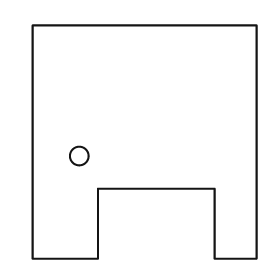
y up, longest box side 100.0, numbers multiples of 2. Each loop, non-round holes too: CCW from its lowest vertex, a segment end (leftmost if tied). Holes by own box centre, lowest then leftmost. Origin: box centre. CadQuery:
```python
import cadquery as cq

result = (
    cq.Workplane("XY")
    .moveTo(-48.0, -50.0)
    .lineTo(-20.0, -50.0)
    .lineTo(-20.0, -20.0)
    .lineTo(30.0, -20.0)
    .lineTo(30.0, -50.0)
    .lineTo(48.0, -50.0)
    .lineTo(48.0, 50.0)
    .lineTo(-48.0, 50.0)
    .close()
    .moveTo(-28.0, -6.0)
    .circle(4.0)
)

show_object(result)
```